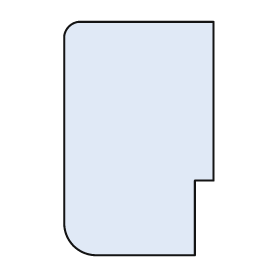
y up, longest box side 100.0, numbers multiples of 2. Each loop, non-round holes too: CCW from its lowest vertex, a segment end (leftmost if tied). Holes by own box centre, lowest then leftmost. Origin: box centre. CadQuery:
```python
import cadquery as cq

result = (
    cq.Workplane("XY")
    .moveTo(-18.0, -50.0)
    .lineTo(24.0, -50.0)
    .lineTo(24.0, -18.0)
    .lineTo(32.0, -18.0)
    .lineTo(32.0, 50.0)
    .lineTo(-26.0, 50.0)
    .threePointArc((-30.0, 48.0), (-32.0, 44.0))
    .lineTo(-32.0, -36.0)
    .threePointArc((-28.0, -46.0), (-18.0, -50.0))
    .close()
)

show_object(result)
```